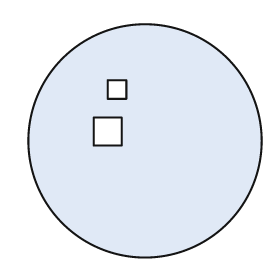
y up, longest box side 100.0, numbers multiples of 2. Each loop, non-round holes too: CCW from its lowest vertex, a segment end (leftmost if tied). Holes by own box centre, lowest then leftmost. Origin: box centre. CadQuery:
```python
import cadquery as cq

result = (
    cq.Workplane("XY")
    .moveTo(0.0, 0.0)
    .circle(50.0)
    .moveTo(-22.0, -2.0)
    .lineTo(-10.0, -2.0)
    .lineTo(-10.0, 10.0)
    .lineTo(-22.0, 10.0)
    .close()
    .moveTo(-16.0, 18.0)
    .lineTo(-8.0, 18.0)
    .lineTo(-8.0, 26.0)
    .lineTo(-16.0, 26.0)
    .close()
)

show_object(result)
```